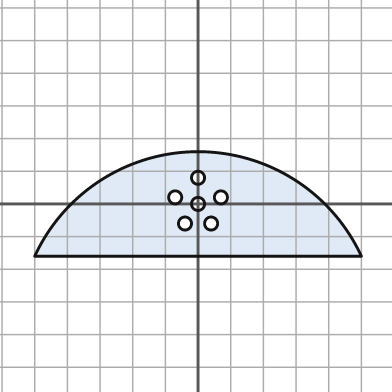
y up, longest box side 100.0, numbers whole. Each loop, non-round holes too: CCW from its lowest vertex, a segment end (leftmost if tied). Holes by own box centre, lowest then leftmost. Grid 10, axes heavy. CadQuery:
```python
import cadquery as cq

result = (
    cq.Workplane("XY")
    .moveTo(-50.0, -16.0)
    .lineTo(50.0, -16.0)
    .threePointArc((0.0, 16.0), (-50.0, -16.0))
    .close()
    .moveTo(-4.0, -6.0)
    .circle(2.0)
    .moveTo(4.0, -6.0)
    .circle(2.0)
    .moveTo(0.0, 0.0)
    .circle(2.0)
    .moveTo(-7.0, 2.0)
    .circle(2.0)
    .moveTo(7.0, 2.0)
    .circle(2.0)
    .moveTo(0.0, 8.0)
    .circle(2.0)
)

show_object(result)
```